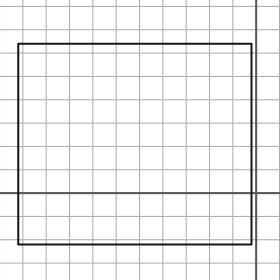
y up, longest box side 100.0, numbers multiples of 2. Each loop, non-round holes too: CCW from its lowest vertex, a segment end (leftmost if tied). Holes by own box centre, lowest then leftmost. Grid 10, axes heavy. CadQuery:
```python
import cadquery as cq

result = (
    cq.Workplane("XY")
    .moveTo(-102.0, -22.0)
    .lineTo(-2.0, -22.0)
    .lineTo(-2.0, 64.0)
    .lineTo(-102.0, 64.0)
    .close()
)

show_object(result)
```